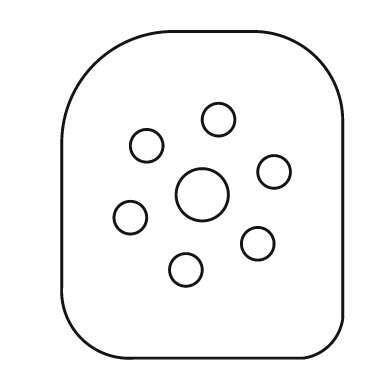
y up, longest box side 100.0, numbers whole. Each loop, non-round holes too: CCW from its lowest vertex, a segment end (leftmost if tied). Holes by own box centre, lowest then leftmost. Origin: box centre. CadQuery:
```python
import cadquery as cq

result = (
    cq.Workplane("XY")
    .moveTo(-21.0, -50.0)
    .lineTo(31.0, -50.0)
    .threePointArc((39.0, -46.0), (43.0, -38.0))
    .lineTo(43.0, 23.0)
    .threePointArc((35.0, 42.0), (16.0, 50.0))
    .lineTo(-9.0, 50.0)
    .threePointArc((-33.0, 40.0), (-43.0, 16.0))
    .lineTo(-43.0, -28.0)
    .threePointArc((-37.0, -44.0), (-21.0, -50.0))
    .close()
    .moveTo(-5.0, -23.0)
    .circle(5.0)
    .moveTo(17.0, -15.0)
    .circle(5.0)
    .moveTo(-22.0, -7.0)
    .circle(5.0)
    .moveTo(0.0, 0.0)
    .circle(8.0)
    .moveTo(22.0, 7.0)
    .circle(5.0)
    .moveTo(-17.0, 15.0)
    .circle(5.0)
    .moveTo(5.0, 23.0)
    .circle(5.0)
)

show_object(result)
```